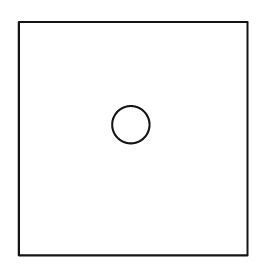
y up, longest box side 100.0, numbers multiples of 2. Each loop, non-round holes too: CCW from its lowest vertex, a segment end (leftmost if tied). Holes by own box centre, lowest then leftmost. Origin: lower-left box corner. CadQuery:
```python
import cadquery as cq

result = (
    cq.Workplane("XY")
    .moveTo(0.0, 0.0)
    .lineTo(98.0, 0.0)
    .lineTo(98.0, 100.0)
    .lineTo(0.0, 100.0)
    .close()
    .moveTo(48.0, 56.0)
    .circle(8.0)
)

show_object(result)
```